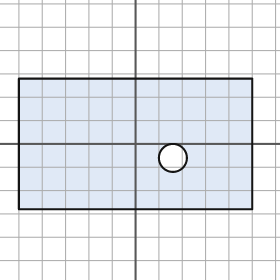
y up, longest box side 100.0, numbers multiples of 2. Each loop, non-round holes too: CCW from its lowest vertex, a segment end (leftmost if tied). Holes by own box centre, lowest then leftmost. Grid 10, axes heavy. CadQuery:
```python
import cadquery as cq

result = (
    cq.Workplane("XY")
    .moveTo(-50.0, -28.0)
    .lineTo(50.0, -28.0)
    .lineTo(50.0, 28.0)
    .lineTo(-50.0, 28.0)
    .close()
    .moveTo(16.0, -6.0)
    .circle(6.0)
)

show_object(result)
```